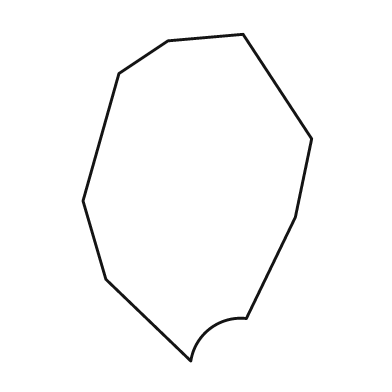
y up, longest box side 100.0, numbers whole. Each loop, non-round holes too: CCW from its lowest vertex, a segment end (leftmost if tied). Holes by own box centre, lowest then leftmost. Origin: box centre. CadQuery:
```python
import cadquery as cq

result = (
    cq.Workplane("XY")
    .moveTo(-2.0, -50.0)
    .threePointArc((4.0, -40.0), (15.0, -37.0))
    .lineTo(30.0, -6.0)
    .lineTo(35.0, 18.0)
    .lineTo(14.0, 50.0)
    .lineTo(-9.0, 48.0)
    .lineTo(-24.0, 38.0)
    .lineTo(-35.0, -1.0)
    .lineTo(-28.0, -25.0)
    .close()
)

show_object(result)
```